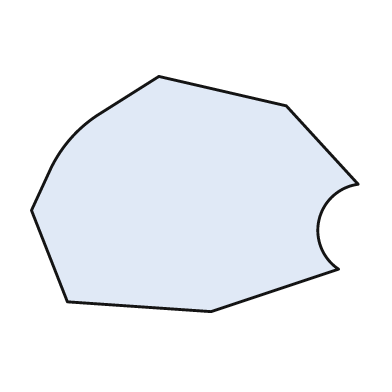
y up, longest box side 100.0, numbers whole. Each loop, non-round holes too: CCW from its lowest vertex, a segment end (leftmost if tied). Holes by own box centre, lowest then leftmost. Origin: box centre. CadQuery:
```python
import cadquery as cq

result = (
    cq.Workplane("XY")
    .moveTo(5.0, -36.0)
    .lineTo(44.0, -23.0)
    .threePointArc((38.0, -8.0), (50.0, 3.0))
    .lineTo(28.0, 27.0)
    .lineTo(-11.0, 36.0)
    .lineTo(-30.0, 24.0)
    .threePointArc((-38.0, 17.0), (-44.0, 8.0))
    .lineTo(-50.0, -5.0)
    .lineTo(-39.0, -33.0)
    .close()
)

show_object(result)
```